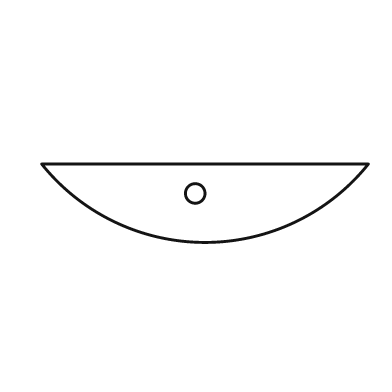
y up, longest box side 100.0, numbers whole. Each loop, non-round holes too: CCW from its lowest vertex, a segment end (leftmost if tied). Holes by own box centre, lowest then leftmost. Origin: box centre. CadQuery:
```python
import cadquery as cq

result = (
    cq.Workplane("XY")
    .moveTo(-50.0, 12.0)
    .threePointArc((0.0, -12.0), (50.0, 12.0))
    .close()
    .moveTo(-3.0, 3.0)
    .circle(3.0)
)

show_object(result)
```